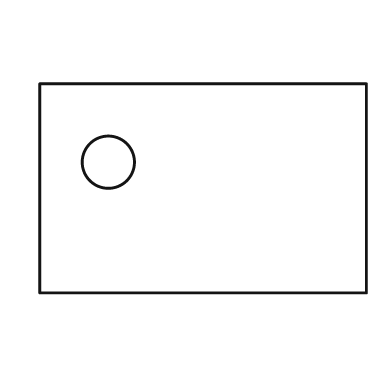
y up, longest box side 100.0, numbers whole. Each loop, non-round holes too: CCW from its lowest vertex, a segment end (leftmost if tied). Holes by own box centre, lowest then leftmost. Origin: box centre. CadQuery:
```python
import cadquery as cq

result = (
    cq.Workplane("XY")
    .moveTo(-50.0, -32.0)
    .lineTo(50.0, -32.0)
    .lineTo(50.0, 32.0)
    .lineTo(-50.0, 32.0)
    .close()
    .moveTo(-29.0, 8.0)
    .circle(8.0)
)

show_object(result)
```